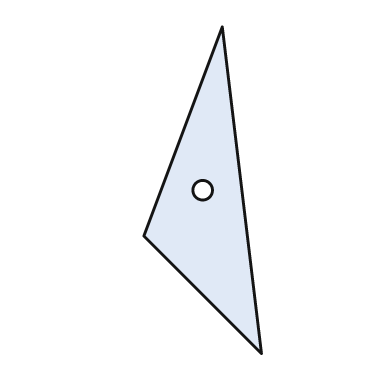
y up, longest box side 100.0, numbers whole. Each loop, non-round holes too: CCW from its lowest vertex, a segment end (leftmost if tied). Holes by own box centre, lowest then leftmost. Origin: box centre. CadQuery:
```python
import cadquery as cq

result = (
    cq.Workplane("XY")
    .moveTo(18.0, -50.0)
    .lineTo(6.0, 50.0)
    .lineTo(-18.0, -14.0)
    .close()
    .moveTo(0.0, 0.0)
    .circle(3.0)
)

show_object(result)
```